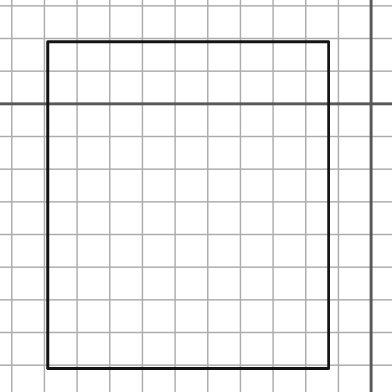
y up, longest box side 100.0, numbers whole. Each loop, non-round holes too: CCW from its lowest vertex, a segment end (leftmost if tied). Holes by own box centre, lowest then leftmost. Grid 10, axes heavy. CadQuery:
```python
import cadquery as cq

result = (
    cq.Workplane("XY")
    .moveTo(-99.0, -81.0)
    .lineTo(-13.0, -81.0)
    .lineTo(-13.0, 19.0)
    .lineTo(-99.0, 19.0)
    .close()
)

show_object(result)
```